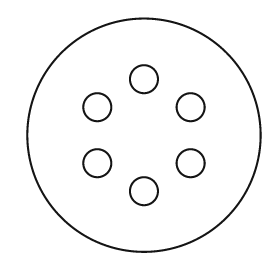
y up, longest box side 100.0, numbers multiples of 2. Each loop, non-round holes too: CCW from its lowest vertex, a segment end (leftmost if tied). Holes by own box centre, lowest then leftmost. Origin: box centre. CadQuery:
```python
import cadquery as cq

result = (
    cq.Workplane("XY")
    .moveTo(0.0, 0.0)
    .circle(50.0)
    .moveTo(0.0, -24.0)
    .circle(6.0)
    .moveTo(-20.0, -12.0)
    .circle(6.0)
    .moveTo(20.0, -12.0)
    .circle(6.0)
    .moveTo(-20.0, 12.0)
    .circle(6.0)
    .moveTo(20.0, 12.0)
    .circle(6.0)
    .moveTo(0.0, 24.0)
    .circle(6.0)
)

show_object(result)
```